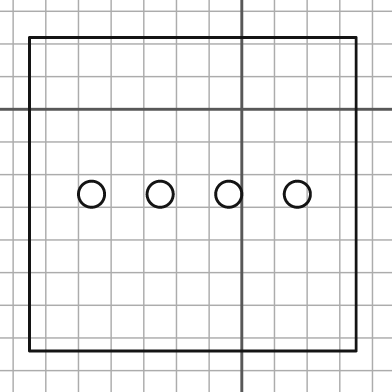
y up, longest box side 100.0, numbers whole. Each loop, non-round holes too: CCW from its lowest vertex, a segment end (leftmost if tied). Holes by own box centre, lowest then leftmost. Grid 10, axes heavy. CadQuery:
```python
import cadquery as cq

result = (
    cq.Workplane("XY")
    .moveTo(-65.0, -74.0)
    .lineTo(35.0, -74.0)
    .lineTo(35.0, 22.0)
    .lineTo(-65.0, 22.0)
    .close()
    .moveTo(-46.0, -26.0)
    .circle(4.0)
    .moveTo(-25.0, -26.0)
    .circle(4.0)
    .moveTo(-4.0, -26.0)
    .circle(4.0)
    .moveTo(17.0, -26.0)
    .circle(4.0)
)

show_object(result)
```